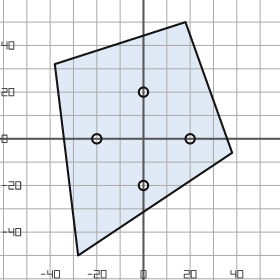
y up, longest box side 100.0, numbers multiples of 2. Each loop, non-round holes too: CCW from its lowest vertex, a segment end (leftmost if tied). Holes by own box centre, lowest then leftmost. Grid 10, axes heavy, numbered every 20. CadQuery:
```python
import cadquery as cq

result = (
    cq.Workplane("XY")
    .moveTo(-28.0, -50.0)
    .lineTo(38.0, -6.0)
    .lineTo(18.0, 50.0)
    .lineTo(-38.0, 32.0)
    .close()
    .moveTo(0.0, -20.0)
    .circle(2.0)
    .moveTo(-20.0, 0.0)
    .circle(2.0)
    .moveTo(20.0, 0.0)
    .circle(2.0)
    .moveTo(0.0, 20.0)
    .circle(2.0)
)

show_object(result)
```